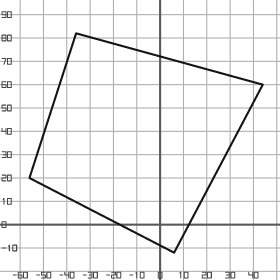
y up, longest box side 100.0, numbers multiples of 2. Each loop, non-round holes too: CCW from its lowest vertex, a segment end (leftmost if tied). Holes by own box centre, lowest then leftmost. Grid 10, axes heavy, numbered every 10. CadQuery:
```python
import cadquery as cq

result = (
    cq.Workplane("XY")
    .moveTo(6.0, -12.0)
    .lineTo(44.0, 60.0)
    .lineTo(-36.0, 82.0)
    .lineTo(-56.0, 20.0)
    .close()
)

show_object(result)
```